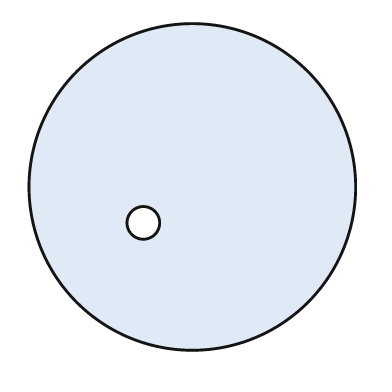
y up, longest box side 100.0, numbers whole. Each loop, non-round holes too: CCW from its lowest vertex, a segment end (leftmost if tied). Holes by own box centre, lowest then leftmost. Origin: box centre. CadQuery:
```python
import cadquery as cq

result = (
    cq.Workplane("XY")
    .moveTo(0.0, 0.0)
    .circle(50.0)
    .moveTo(-15.0, -11.0)
    .circle(5.0)
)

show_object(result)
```